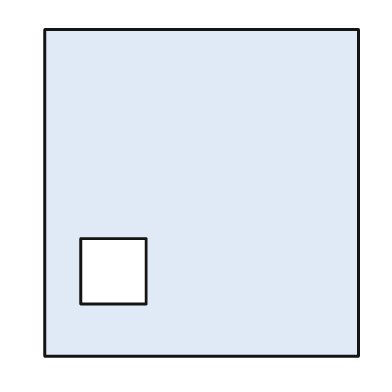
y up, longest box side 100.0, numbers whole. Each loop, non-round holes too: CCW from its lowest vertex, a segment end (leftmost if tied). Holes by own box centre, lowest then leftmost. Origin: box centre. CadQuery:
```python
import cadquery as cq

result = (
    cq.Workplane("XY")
    .moveTo(-48.0, -50.0)
    .lineTo(48.0, -50.0)
    .lineTo(48.0, 50.0)
    .lineTo(-48.0, 50.0)
    .close()
    .moveTo(-37.0, -34.0)
    .lineTo(-17.0, -34.0)
    .lineTo(-17.0, -14.0)
    .lineTo(-37.0, -14.0)
    .close()
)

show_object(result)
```